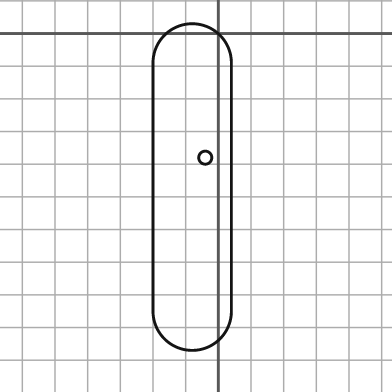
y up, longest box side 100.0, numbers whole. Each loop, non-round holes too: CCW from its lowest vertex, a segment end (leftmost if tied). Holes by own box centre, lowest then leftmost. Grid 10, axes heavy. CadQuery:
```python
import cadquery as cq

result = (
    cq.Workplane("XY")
    .moveTo(-20.0, -85.0)
    .threePointArc((-8.0, -97.0), (4.0, -85.0))
    .lineTo(4.0, -9.0)
    .threePointArc((-8.0, 3.0), (-20.0, -9.0))
    .close()
    .moveTo(-4.0, -38.0)
    .circle(2.0)
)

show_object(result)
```